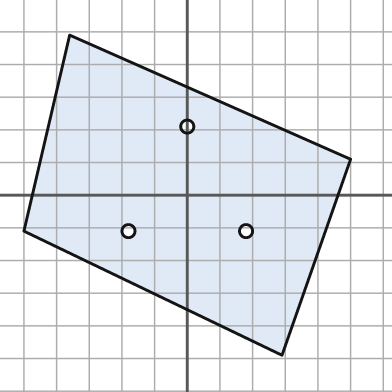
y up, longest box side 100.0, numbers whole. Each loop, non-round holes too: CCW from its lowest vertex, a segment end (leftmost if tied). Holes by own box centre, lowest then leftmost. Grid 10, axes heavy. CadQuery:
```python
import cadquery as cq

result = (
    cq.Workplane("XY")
    .moveTo(29.0, -49.0)
    .lineTo(50.0, 11.0)
    .lineTo(-36.0, 49.0)
    .lineTo(-50.0, -11.0)
    .close()
    .moveTo(-18.0, -11.0)
    .circle(2.0)
    .moveTo(18.0, -11.0)
    .circle(2.0)
    .moveTo(0.0, 21.0)
    .circle(2.0)
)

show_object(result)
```